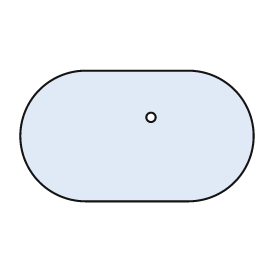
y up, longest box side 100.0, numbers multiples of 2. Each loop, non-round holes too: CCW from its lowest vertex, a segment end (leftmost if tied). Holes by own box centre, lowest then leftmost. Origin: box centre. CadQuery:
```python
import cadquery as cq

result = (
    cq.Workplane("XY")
    .moveTo(-22.0, -28.0)
    .lineTo(22.0, -28.0)
    .threePointArc((50.0, 0.0), (22.0, 28.0))
    .lineTo(-22.0, 28.0)
    .threePointArc((-50.0, 0.0), (-22.0, -28.0))
    .close()
    .moveTo(6.0, 8.0)
    .circle(2.0)
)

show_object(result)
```